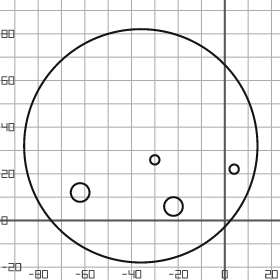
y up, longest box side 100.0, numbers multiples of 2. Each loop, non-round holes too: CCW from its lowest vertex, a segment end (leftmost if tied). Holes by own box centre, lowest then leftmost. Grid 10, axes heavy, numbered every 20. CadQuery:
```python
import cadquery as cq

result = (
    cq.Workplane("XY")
    .moveTo(-36.0, 32.0)
    .circle(50.0)
    .moveTo(-22.0, 6.0)
    .circle(4.0)
    .moveTo(-62.0, 12.0)
    .circle(4.0)
    .moveTo(4.0, 22.0)
    .circle(2.0)
    .moveTo(-30.0, 26.0)
    .circle(2.0)
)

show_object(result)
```